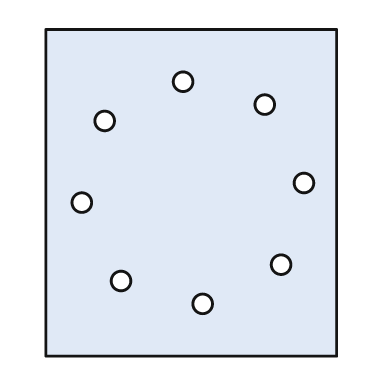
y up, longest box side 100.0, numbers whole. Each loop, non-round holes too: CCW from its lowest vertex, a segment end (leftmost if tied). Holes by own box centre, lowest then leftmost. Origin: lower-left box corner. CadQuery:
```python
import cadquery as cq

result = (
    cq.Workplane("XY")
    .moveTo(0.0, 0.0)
    .lineTo(89.0, 0.0)
    .lineTo(89.0, 100.0)
    .lineTo(0.0, 100.0)
    .close()
    .moveTo(48.0, 16.0)
    .circle(3.0)
    .moveTo(23.0, 23.0)
    .circle(3.0)
    .moveTo(72.0, 28.0)
    .circle(3.0)
    .moveTo(11.0, 47.0)
    .circle(3.0)
    .moveTo(79.0, 53.0)
    .circle(3.0)
    .moveTo(18.0, 72.0)
    .circle(3.0)
    .moveTo(67.0, 77.0)
    .circle(3.0)
    .moveTo(42.0, 84.0)
    .circle(3.0)
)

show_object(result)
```